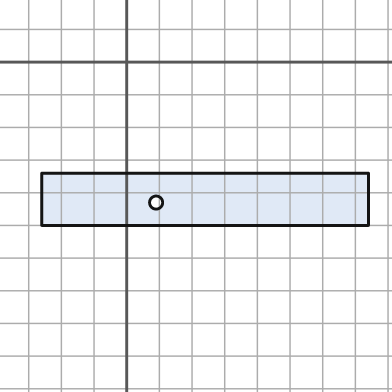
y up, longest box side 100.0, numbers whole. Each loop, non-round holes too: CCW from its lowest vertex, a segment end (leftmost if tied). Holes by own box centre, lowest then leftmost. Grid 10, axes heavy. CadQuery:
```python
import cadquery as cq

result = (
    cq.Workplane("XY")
    .moveTo(-26.0, -50.0)
    .lineTo(74.0, -50.0)
    .lineTo(74.0, -34.0)
    .lineTo(-26.0, -34.0)
    .close()
    .moveTo(9.0, -43.0)
    .circle(2.0)
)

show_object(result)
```